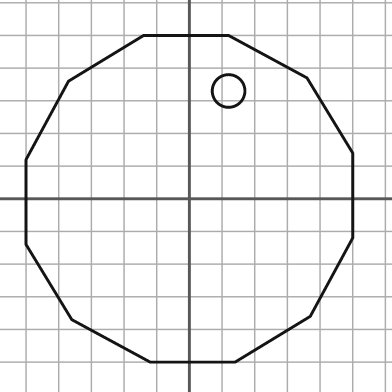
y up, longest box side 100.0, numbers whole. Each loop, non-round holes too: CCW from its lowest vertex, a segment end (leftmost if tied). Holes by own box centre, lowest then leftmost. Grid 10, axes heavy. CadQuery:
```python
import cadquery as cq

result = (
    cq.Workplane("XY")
    .moveTo(-12.0, -50.0)
    .lineTo(14.0, -50.0)
    .lineTo(37.0, -36.0)
    .lineTo(50.0, -12.0)
    .lineTo(50.0, 14.0)
    .lineTo(36.0, 37.0)
    .lineTo(12.0, 50.0)
    .lineTo(-14.0, 50.0)
    .lineTo(-37.0, 36.0)
    .lineTo(-50.0, 12.0)
    .lineTo(-50.0, -14.0)
    .lineTo(-36.0, -37.0)
    .close()
    .moveTo(12.0, 33.0)
    .circle(5.0)
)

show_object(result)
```